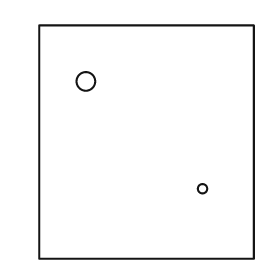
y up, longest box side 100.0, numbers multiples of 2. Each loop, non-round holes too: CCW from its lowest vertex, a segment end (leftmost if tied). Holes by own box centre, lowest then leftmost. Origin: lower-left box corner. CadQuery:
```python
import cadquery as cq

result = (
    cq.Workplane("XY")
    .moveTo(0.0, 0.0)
    .lineTo(92.0, 0.0)
    .lineTo(92.0, 100.0)
    .lineTo(0.0, 100.0)
    .close()
    .moveTo(70.0, 30.0)
    .circle(2.0)
    .moveTo(20.0, 76.0)
    .circle(4.0)
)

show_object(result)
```